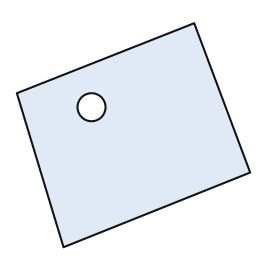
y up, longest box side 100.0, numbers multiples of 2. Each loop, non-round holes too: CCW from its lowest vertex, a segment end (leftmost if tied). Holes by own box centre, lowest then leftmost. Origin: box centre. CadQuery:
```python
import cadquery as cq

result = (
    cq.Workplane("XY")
    .moveTo(-30.0, -48.0)
    .lineTo(50.0, -16.0)
    .lineTo(26.0, 48.0)
    .lineTo(-50.0, 18.0)
    .close()
    .moveTo(-18.0, 12.0)
    .circle(6.0)
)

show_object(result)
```